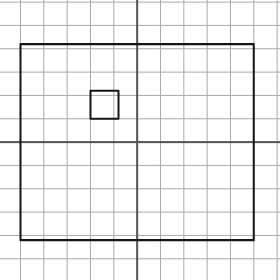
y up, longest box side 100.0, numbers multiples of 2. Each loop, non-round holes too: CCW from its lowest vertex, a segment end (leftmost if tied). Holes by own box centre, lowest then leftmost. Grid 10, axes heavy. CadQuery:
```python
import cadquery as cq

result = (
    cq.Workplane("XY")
    .moveTo(-50.0, -42.0)
    .lineTo(50.0, -42.0)
    .lineTo(50.0, 42.0)
    .lineTo(-50.0, 42.0)
    .close()
    .moveTo(-20.0, 10.0)
    .lineTo(-8.0, 10.0)
    .lineTo(-8.0, 22.0)
    .lineTo(-20.0, 22.0)
    .close()
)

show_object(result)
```